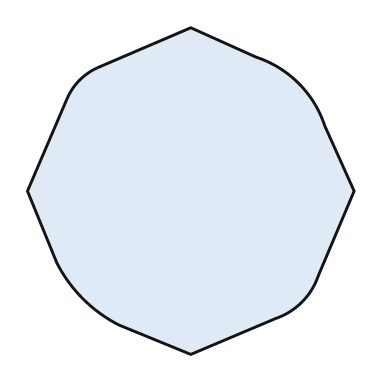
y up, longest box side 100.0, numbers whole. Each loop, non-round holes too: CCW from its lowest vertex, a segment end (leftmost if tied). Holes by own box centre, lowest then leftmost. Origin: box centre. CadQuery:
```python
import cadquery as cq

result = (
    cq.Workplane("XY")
    .moveTo(0.0, -50.0)
    .lineTo(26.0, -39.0)
    .threePointArc((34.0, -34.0), (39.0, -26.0))
    .lineTo(50.0, 0.0)
    .lineTo(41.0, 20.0)
    .threePointArc((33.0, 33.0), (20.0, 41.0))
    .lineTo(0.0, 50.0)
    .lineTo(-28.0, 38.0)
    .threePointArc((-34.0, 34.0), (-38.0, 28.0))
    .lineTo(-50.0, 0.0)
    .lineTo(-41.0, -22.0)
    .threePointArc((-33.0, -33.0), (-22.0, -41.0))
    .close()
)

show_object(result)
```